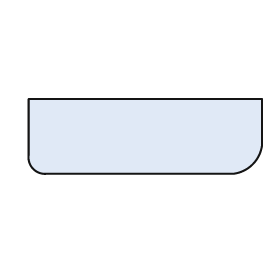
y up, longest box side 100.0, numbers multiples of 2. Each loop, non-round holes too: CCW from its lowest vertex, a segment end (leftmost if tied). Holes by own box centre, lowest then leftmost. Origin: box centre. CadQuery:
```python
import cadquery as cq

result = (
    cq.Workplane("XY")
    .moveTo(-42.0, -16.0)
    .lineTo(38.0, -16.0)
    .threePointArc((46.0, -12.0), (50.0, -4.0))
    .lineTo(50.0, 16.0)
    .lineTo(-50.0, 16.0)
    .lineTo(-50.0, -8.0)
    .threePointArc((-48.0, -14.0), (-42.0, -16.0))
    .close()
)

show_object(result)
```